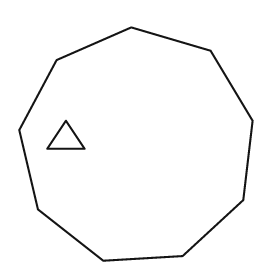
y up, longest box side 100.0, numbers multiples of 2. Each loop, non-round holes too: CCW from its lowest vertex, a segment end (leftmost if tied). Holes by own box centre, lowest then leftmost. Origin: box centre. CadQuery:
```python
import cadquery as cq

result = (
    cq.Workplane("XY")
    .moveTo(-14.0, -50.0)
    .lineTo(20.0, -48.0)
    .lineTo(46.0, -24.0)
    .lineTo(50.0, 10.0)
    .lineTo(32.0, 40.0)
    .lineTo(-2.0, 50.0)
    .lineTo(-34.0, 36.0)
    .lineTo(-50.0, 6.0)
    .lineTo(-42.0, -28.0)
    .close()
    .moveTo(-38.0, -2.0)
    .lineTo(-22.0, -2.0)
    .lineTo(-30.0, 10.0)
    .close()
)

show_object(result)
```